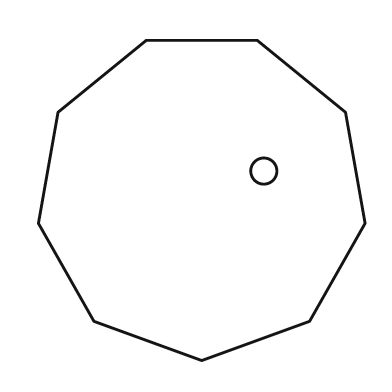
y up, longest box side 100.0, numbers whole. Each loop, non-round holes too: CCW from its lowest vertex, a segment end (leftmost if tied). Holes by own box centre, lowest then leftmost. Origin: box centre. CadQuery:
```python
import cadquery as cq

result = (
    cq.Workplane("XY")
    .moveTo(0.0, -49.0)
    .lineTo(33.0, -37.0)
    .lineTo(50.0, -7.0)
    .lineTo(44.0, 27.0)
    .lineTo(17.0, 49.0)
    .lineTo(-17.0, 49.0)
    .lineTo(-44.0, 27.0)
    .lineTo(-50.0, -7.0)
    .lineTo(-33.0, -37.0)
    .close()
    .moveTo(19.0, 9.0)
    .circle(4.0)
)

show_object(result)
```